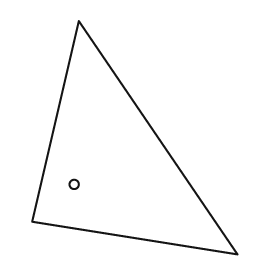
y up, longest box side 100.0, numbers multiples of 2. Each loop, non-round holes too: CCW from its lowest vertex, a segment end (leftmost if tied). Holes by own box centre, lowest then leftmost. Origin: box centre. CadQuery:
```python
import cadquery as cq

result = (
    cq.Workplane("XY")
    .moveTo(44.0, -50.0)
    .lineTo(-24.0, 50.0)
    .lineTo(-44.0, -36.0)
    .close()
    .moveTo(-26.0, -20.0)
    .circle(2.0)
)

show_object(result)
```